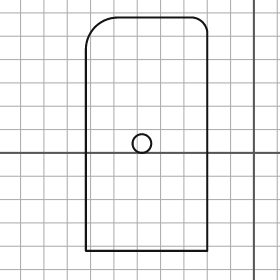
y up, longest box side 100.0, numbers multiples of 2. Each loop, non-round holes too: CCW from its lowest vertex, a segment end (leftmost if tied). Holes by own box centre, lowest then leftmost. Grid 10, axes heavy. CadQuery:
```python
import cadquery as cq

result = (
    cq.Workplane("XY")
    .moveTo(-72.0, -42.0)
    .lineTo(-20.0, -42.0)
    .lineTo(-20.0, 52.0)
    .threePointArc((-22.0, 56.0), (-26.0, 58.0))
    .lineTo(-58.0, 58.0)
    .threePointArc((-68.0, 54.0), (-72.0, 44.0))
    .close()
    .moveTo(-48.0, 4.0)
    .circle(4.0)
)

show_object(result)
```